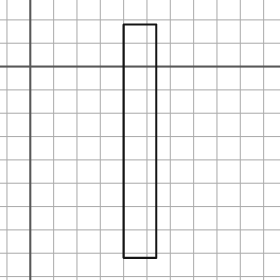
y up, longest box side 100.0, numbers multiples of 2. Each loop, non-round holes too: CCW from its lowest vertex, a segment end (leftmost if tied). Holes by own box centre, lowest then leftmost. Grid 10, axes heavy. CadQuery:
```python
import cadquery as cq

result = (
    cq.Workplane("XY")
    .moveTo(40.0, -82.0)
    .lineTo(54.0, -82.0)
    .lineTo(54.0, 18.0)
    .lineTo(40.0, 18.0)
    .close()
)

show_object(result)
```